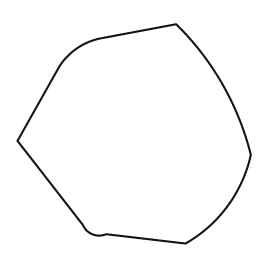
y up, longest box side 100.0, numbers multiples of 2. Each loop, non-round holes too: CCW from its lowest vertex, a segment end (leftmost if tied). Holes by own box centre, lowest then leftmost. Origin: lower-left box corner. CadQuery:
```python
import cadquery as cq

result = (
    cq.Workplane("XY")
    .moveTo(72.0, 0.0)
    .threePointArc((90.0, 16.0), (100.0, 38.0))
    .threePointArc((88.0, 68.0), (68.0, 94.0))
    .lineTo(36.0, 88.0)
    .threePointArc((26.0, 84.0), (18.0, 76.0))
    .lineTo(0.0, 44.0)
    .lineTo(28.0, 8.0)
    .threePointArc((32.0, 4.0), (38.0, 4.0))
    .close()
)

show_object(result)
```